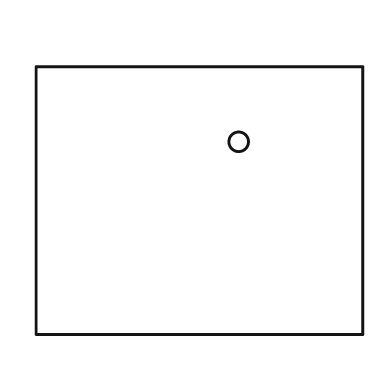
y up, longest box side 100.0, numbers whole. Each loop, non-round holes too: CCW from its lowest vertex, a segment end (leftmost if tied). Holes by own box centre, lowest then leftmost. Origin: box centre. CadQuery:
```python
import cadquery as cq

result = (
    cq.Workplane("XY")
    .moveTo(-50.0, -41.0)
    .lineTo(50.0, -41.0)
    .lineTo(50.0, 41.0)
    .lineTo(-50.0, 41.0)
    .close()
    .moveTo(12.0, 18.0)
    .circle(3.0)
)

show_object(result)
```